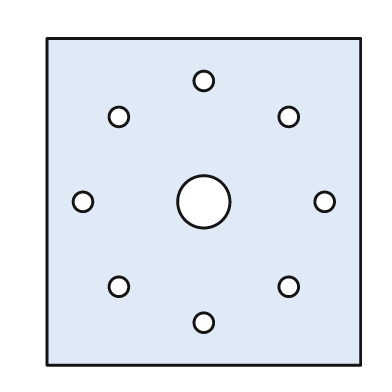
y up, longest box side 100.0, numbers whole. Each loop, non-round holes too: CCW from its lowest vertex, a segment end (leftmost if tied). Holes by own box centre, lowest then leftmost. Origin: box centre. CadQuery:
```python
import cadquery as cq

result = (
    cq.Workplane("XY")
    .moveTo(-48.0, -50.0)
    .lineTo(48.0, -50.0)
    .lineTo(48.0, 50.0)
    .lineTo(-48.0, 50.0)
    .close()
    .moveTo(0.0, -37.0)
    .circle(3.0)
    .moveTo(-26.0, -26.0)
    .circle(3.0)
    .moveTo(26.0, -26.0)
    .circle(3.0)
    .moveTo(-37.0, 0.0)
    .circle(3.0)
    .moveTo(0.0, 0.0)
    .circle(8.0)
    .moveTo(37.0, 0.0)
    .circle(3.0)
    .moveTo(-26.0, 26.0)
    .circle(3.0)
    .moveTo(26.0, 26.0)
    .circle(3.0)
    .moveTo(0.0, 37.0)
    .circle(3.0)
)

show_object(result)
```